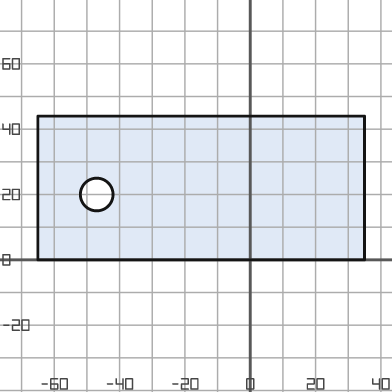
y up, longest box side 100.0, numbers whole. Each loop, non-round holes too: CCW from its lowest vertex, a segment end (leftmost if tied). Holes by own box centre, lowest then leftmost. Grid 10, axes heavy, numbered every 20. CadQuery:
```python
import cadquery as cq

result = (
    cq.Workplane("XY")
    .moveTo(-65.0, 0.0)
    .lineTo(35.0, 0.0)
    .lineTo(35.0, 44.0)
    .lineTo(-65.0, 44.0)
    .close()
    .moveTo(-47.0, 20.0)
    .circle(5.0)
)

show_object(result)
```